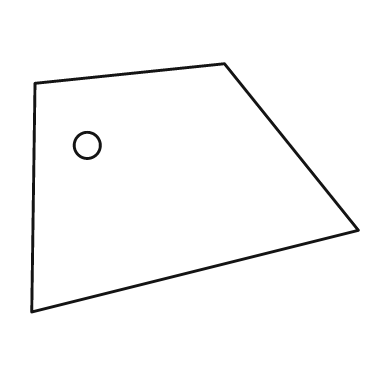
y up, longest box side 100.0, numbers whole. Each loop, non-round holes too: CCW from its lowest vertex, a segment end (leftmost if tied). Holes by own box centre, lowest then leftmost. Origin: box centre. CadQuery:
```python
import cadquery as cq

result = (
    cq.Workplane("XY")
    .moveTo(-50.0, -38.0)
    .lineTo(50.0, -13.0)
    .lineTo(9.0, 38.0)
    .lineTo(-49.0, 32.0)
    .close()
    .moveTo(-33.0, 13.0)
    .circle(4.0)
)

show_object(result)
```